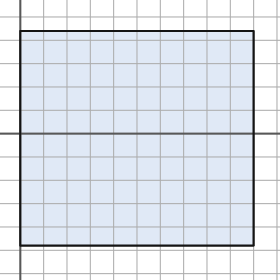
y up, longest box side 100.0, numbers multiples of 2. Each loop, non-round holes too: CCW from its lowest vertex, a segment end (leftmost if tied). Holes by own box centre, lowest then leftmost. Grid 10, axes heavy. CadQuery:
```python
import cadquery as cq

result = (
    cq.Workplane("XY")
    .moveTo(0.0, -48.0)
    .lineTo(100.0, -48.0)
    .lineTo(100.0, 44.0)
    .lineTo(0.0, 44.0)
    .close()
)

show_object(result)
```